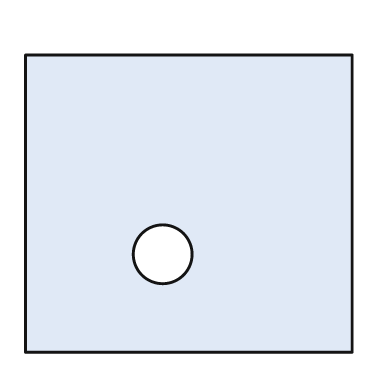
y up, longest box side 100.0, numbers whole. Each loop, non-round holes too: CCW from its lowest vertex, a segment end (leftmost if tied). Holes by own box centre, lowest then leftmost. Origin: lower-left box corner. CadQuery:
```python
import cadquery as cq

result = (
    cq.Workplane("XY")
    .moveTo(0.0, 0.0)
    .lineTo(100.0, 0.0)
    .lineTo(100.0, 91.0)
    .lineTo(0.0, 91.0)
    .close()
    .moveTo(42.0, 30.0)
    .circle(9.0)
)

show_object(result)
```